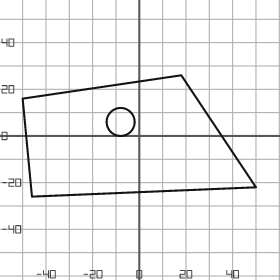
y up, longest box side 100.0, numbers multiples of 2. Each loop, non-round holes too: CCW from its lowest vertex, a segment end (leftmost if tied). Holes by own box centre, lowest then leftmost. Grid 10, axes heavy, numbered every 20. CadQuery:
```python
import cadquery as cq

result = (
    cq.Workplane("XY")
    .moveTo(-46.0, -26.0)
    .lineTo(50.0, -22.0)
    .lineTo(18.0, 26.0)
    .lineTo(-50.0, 16.0)
    .close()
    .moveTo(-8.0, 6.0)
    .circle(6.0)
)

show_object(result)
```